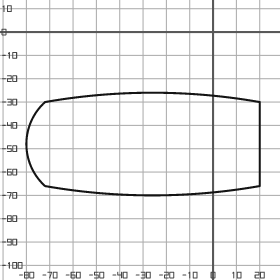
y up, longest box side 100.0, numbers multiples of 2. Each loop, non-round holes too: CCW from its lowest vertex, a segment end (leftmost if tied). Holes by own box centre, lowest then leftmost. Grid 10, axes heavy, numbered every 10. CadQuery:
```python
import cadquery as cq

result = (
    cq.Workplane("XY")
    .moveTo(-72.0, -66.0)
    .threePointArc((-26.0, -70.0), (20.0, -66.0))
    .lineTo(20.0, -30.0)
    .threePointArc((-26.0, -26.0), (-72.0, -30.0))
    .threePointArc((-80.0, -48.0), (-72.0, -66.0))
    .close()
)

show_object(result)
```